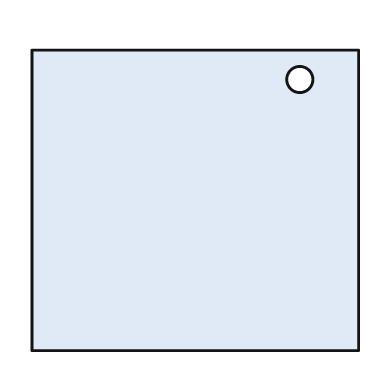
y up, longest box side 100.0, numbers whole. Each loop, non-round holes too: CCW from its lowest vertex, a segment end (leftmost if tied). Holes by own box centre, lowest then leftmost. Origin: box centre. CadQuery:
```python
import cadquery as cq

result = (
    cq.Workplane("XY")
    .moveTo(-50.0, -46.0)
    .lineTo(50.0, -46.0)
    .lineTo(50.0, 46.0)
    .lineTo(-50.0, 46.0)
    .close()
    .moveTo(32.0, 37.0)
    .circle(4.0)
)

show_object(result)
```